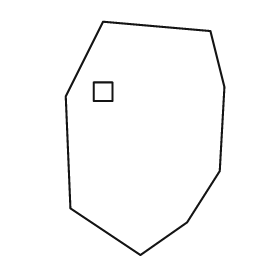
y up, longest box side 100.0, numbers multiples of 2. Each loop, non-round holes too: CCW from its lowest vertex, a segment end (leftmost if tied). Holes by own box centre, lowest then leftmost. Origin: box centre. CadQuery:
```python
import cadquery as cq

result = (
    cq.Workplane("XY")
    .moveTo(-2.0, -50.0)
    .lineTo(18.0, -36.0)
    .lineTo(32.0, -14.0)
    .lineTo(34.0, 22.0)
    .lineTo(28.0, 46.0)
    .lineTo(-18.0, 50.0)
    .lineTo(-34.0, 18.0)
    .lineTo(-32.0, -30.0)
    .close()
    .moveTo(-22.0, 16.0)
    .lineTo(-14.0, 16.0)
    .lineTo(-14.0, 24.0)
    .lineTo(-22.0, 24.0)
    .close()
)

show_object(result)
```